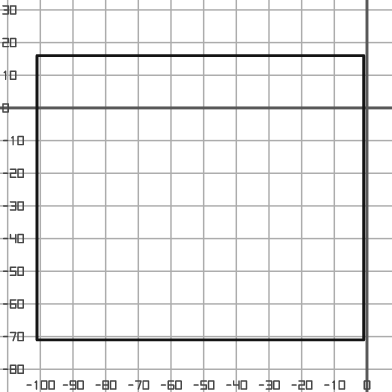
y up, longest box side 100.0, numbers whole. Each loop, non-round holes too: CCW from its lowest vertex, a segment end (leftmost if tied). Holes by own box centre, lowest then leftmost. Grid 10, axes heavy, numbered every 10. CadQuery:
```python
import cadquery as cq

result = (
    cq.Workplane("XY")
    .moveTo(-101.0, -71.0)
    .lineTo(-1.0, -71.0)
    .lineTo(-1.0, 16.0)
    .lineTo(-101.0, 16.0)
    .close()
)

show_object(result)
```